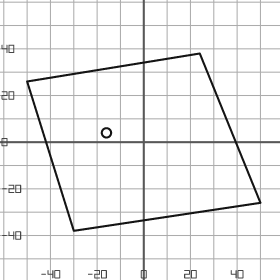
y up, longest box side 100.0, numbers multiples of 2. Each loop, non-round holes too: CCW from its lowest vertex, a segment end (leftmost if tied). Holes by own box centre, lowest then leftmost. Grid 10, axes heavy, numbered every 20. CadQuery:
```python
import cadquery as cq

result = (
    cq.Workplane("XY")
    .moveTo(-30.0, -38.0)
    .lineTo(50.0, -26.0)
    .lineTo(24.0, 38.0)
    .lineTo(-50.0, 26.0)
    .close()
    .moveTo(-16.0, 4.0)
    .circle(2.0)
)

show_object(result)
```